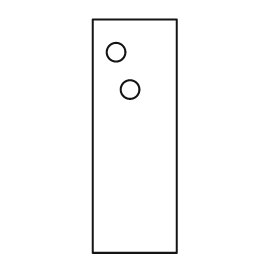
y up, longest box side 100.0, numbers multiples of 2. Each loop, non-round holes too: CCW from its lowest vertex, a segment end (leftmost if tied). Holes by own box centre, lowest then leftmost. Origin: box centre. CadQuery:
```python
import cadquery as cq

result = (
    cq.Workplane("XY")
    .moveTo(-18.0, -50.0)
    .lineTo(18.0, -50.0)
    .lineTo(18.0, 50.0)
    .lineTo(-18.0, 50.0)
    .close()
    .moveTo(-2.0, 20.0)
    .circle(4.0)
    .moveTo(-8.0, 36.0)
    .circle(4.0)
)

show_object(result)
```